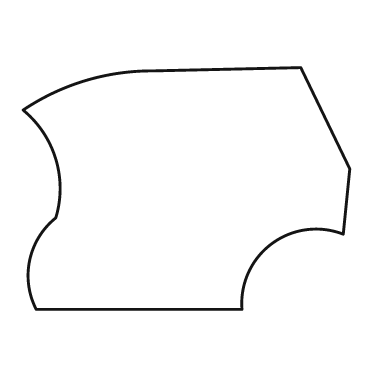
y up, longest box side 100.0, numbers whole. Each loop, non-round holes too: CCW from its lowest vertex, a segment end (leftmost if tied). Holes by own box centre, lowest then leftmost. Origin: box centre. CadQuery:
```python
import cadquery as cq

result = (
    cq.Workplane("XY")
    .moveTo(-46.0, -37.0)
    .lineTo(17.0, -37.0)
    .threePointArc((26.0, -17.0), (48.0, -14.0))
    .lineTo(50.0, 6.0)
    .lineTo(35.0, 37.0)
    .lineTo(-10.0, 36.0)
    .threePointArc((-31.0, 33.0), (-50.0, 24.0))
    .threePointArc((-40.0, 9.0), (-40.0, -9.0))
    .threePointArc((-48.0, -22.0), (-46.0, -37.0))
    .close()
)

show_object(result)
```